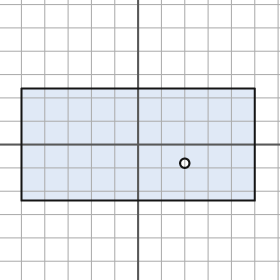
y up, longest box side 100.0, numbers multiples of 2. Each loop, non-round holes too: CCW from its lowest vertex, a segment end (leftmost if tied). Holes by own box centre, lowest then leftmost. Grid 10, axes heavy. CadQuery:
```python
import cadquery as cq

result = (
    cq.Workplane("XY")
    .moveTo(-50.0, -24.0)
    .lineTo(50.0, -24.0)
    .lineTo(50.0, 24.0)
    .lineTo(-50.0, 24.0)
    .close()
    .moveTo(20.0, -8.0)
    .circle(2.0)
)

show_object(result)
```